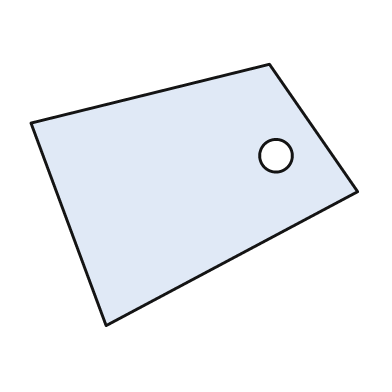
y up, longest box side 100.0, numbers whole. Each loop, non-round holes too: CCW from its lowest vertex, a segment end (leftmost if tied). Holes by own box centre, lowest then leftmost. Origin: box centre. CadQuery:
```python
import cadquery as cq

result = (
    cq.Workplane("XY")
    .moveTo(-27.0, -40.0)
    .lineTo(50.0, 1.0)
    .lineTo(23.0, 40.0)
    .lineTo(-50.0, 22.0)
    .close()
    .moveTo(25.0, 12.0)
    .circle(5.0)
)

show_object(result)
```